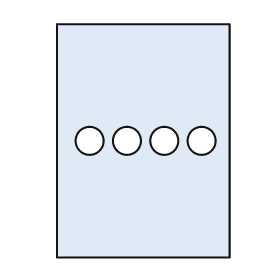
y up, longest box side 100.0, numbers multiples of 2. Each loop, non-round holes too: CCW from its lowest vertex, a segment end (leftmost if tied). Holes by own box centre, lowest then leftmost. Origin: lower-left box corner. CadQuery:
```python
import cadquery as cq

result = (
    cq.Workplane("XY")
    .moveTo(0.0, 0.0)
    .lineTo(74.0, 0.0)
    .lineTo(74.0, 100.0)
    .lineTo(0.0, 100.0)
    .close()
    .moveTo(14.0, 50.0)
    .circle(6.0)
    .moveTo(30.0, 50.0)
    .circle(6.0)
    .moveTo(46.0, 50.0)
    .circle(6.0)
    .moveTo(62.0, 50.0)
    .circle(6.0)
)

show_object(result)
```